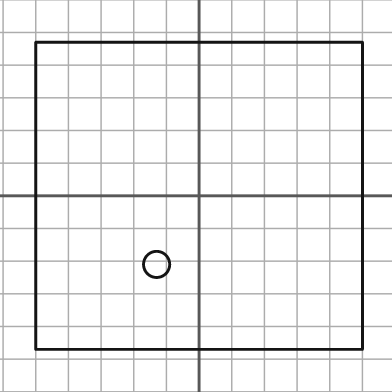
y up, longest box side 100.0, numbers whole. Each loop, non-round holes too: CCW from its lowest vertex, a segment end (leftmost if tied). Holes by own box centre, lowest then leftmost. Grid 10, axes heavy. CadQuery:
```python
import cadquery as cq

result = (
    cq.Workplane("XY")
    .moveTo(-50.0, -47.0)
    .lineTo(50.0, -47.0)
    .lineTo(50.0, 47.0)
    .lineTo(-50.0, 47.0)
    .close()
    .moveTo(-13.0, -21.0)
    .circle(4.0)
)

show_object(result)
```